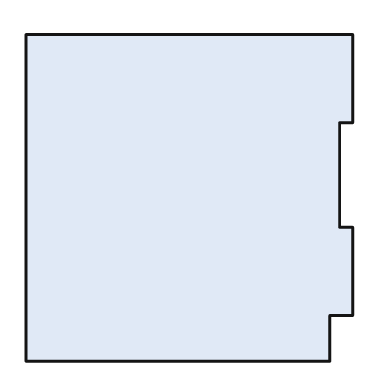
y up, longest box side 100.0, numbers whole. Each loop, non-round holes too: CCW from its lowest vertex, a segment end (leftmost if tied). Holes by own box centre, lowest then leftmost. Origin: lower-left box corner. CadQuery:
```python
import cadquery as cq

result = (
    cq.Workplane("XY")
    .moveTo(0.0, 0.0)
    .lineTo(93.0, 0.0)
    .lineTo(93.0, 14.0)
    .lineTo(100.0, 14.0)
    .lineTo(100.0, 41.0)
    .lineTo(96.0, 41.0)
    .lineTo(96.0, 73.0)
    .lineTo(100.0, 73.0)
    .lineTo(100.0, 100.0)
    .lineTo(0.0, 100.0)
    .close()
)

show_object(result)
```